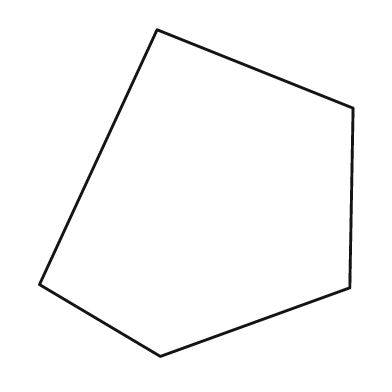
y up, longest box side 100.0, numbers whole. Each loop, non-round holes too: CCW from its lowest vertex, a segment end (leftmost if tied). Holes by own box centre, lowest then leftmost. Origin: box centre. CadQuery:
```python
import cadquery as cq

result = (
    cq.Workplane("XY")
    .moveTo(-11.0, -50.0)
    .lineTo(47.0, -29.0)
    .lineTo(48.0, 26.0)
    .lineTo(-12.0, 50.0)
    .lineTo(-48.0, -28.0)
    .close()
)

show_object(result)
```